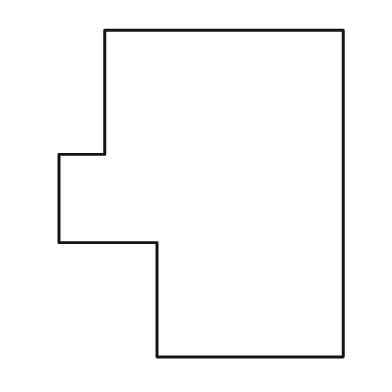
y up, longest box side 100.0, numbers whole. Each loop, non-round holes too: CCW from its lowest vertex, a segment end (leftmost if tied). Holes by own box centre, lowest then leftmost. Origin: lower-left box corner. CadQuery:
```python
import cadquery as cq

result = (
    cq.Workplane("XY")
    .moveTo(30.0, 0.0)
    .lineTo(87.0, 0.0)
    .lineTo(87.0, 100.0)
    .lineTo(14.0, 100.0)
    .lineTo(14.0, 62.0)
    .lineTo(0.0, 62.0)
    .lineTo(0.0, 35.0)
    .lineTo(30.0, 35.0)
    .close()
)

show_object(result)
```